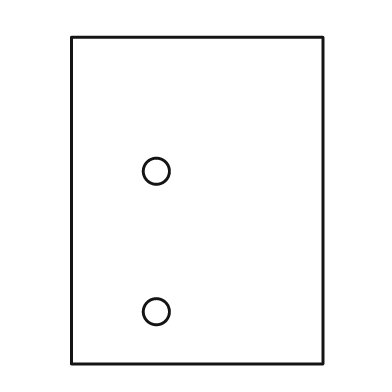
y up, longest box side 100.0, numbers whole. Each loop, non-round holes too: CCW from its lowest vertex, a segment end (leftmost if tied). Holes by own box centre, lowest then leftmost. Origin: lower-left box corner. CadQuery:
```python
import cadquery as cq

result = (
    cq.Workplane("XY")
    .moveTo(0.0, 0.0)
    .lineTo(77.0, 0.0)
    .lineTo(77.0, 100.0)
    .lineTo(0.0, 100.0)
    .close()
    .moveTo(26.0, 16.0)
    .circle(4.0)
    .moveTo(26.0, 59.0)
    .circle(4.0)
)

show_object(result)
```